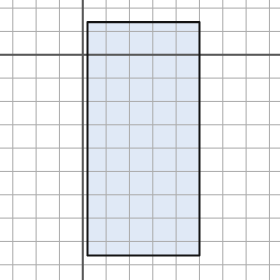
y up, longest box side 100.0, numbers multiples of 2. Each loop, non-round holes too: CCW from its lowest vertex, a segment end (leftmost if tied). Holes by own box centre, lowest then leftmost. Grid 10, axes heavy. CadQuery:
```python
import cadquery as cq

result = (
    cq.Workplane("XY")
    .moveTo(2.0, -86.0)
    .lineTo(50.0, -86.0)
    .lineTo(50.0, 14.0)
    .lineTo(2.0, 14.0)
    .close()
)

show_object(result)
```